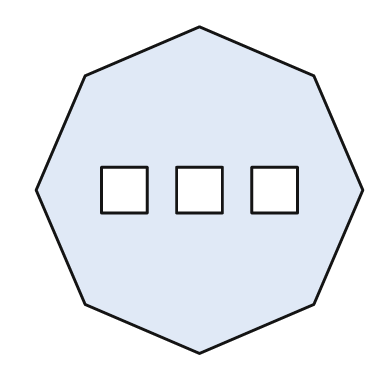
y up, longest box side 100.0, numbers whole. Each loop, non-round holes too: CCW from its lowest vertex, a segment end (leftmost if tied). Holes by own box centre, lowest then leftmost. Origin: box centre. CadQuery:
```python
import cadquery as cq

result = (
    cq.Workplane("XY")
    .moveTo(0.0, -50.0)
    .lineTo(35.0, -35.0)
    .lineTo(50.0, 0.0)
    .lineTo(35.0, 35.0)
    .lineTo(0.0, 50.0)
    .lineTo(-35.0, 35.0)
    .lineTo(-50.0, 0.0)
    .lineTo(-35.0, -35.0)
    .close()
    .moveTo(-30.0, -7.0)
    .lineTo(-16.0, -7.0)
    .lineTo(-16.0, 7.0)
    .lineTo(-30.0, 7.0)
    .close()
    .moveTo(-7.0, -7.0)
    .lineTo(7.0, -7.0)
    .lineTo(7.0, 7.0)
    .lineTo(-7.0, 7.0)
    .close()
    .moveTo(16.0, -7.0)
    .lineTo(30.0, -7.0)
    .lineTo(30.0, 7.0)
    .lineTo(16.0, 7.0)
    .close()
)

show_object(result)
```